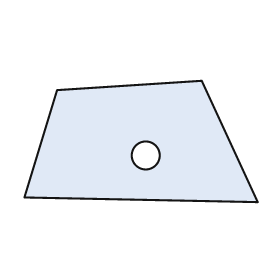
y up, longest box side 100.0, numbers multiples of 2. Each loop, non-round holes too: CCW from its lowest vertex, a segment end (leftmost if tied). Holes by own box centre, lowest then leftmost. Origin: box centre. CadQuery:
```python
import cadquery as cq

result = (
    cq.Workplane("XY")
    .moveTo(50.0, -26.0)
    .lineTo(26.0, 26.0)
    .lineTo(-36.0, 22.0)
    .lineTo(-50.0, -24.0)
    .close()
    .moveTo(2.0, -6.0)
    .circle(6.0)
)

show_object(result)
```